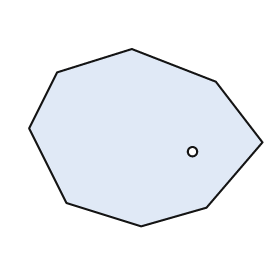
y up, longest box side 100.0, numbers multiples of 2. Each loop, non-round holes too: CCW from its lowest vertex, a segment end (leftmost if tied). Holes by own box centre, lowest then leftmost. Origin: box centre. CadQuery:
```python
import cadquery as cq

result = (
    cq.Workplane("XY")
    .moveTo(-2.0, -38.0)
    .lineTo(26.0, -30.0)
    .lineTo(50.0, -2.0)
    .lineTo(30.0, 24.0)
    .lineTo(-6.0, 38.0)
    .lineTo(-38.0, 28.0)
    .lineTo(-50.0, 4.0)
    .lineTo(-34.0, -28.0)
    .close()
    .moveTo(20.0, -6.0)
    .circle(2.0)
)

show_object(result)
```